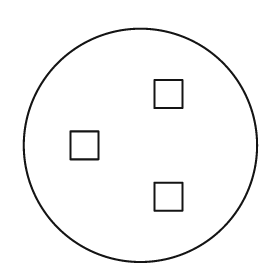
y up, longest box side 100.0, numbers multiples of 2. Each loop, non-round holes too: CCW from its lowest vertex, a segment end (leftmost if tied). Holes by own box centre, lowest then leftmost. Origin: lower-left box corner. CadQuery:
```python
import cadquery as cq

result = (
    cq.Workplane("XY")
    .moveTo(50.0, 50.0)
    .circle(50.0)
    .moveTo(56.0, 22.0)
    .lineTo(68.0, 22.0)
    .lineTo(68.0, 34.0)
    .lineTo(56.0, 34.0)
    .close()
    .moveTo(20.0, 44.0)
    .lineTo(32.0, 44.0)
    .lineTo(32.0, 56.0)
    .lineTo(20.0, 56.0)
    .close()
    .moveTo(56.0, 66.0)
    .lineTo(68.0, 66.0)
    .lineTo(68.0, 78.0)
    .lineTo(56.0, 78.0)
    .close()
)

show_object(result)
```